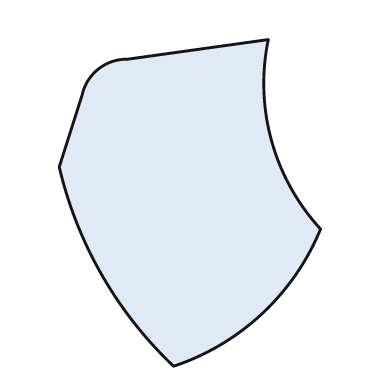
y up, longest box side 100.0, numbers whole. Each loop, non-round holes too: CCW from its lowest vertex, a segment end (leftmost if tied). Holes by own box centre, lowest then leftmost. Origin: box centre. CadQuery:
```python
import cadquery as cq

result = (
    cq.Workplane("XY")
    .moveTo(-5.0, -50.0)
    .threePointArc((22.0, -34.0), (40.0, -8.0))
    .threePointArc((25.0, 19.0), (24.0, 50.0))
    .lineTo(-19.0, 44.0)
    .threePointArc((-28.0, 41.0), (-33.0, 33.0))
    .lineTo(-40.0, 11.0)
    .threePointArc((-27.0, -22.0), (-5.0, -50.0))
    .close()
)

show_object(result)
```